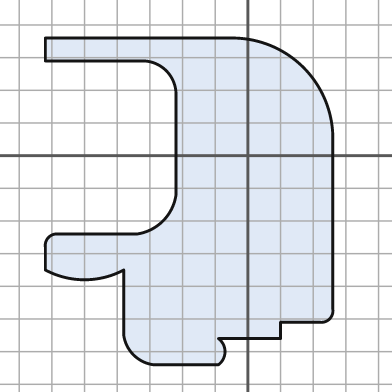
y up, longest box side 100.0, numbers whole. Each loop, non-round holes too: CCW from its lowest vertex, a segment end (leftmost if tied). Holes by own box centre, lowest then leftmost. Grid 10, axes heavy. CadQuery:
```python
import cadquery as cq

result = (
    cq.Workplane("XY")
    .moveTo(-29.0, -64.0)
    .lineTo(-9.0, -64.0)
    .threePointArc((-7.0, -60.0), (-9.0, -56.0))
    .lineTo(10.0, -56.0)
    .lineTo(10.0, -51.0)
    .lineTo(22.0, -51.0)
    .threePointArc((25.0, -50.0), (26.0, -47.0))
    .lineTo(26.0, 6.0)
    .threePointArc((17.0, 27.0), (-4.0, 36.0))
    .lineTo(-62.0, 36.0)
    .lineTo(-62.0, 29.0)
    .lineTo(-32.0, 29.0)
    .threePointArc((-25.0, 26.0), (-22.0, 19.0))
    .lineTo(-22.0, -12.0)
    .threePointArc((-26.0, -20.0), (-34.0, -24.0))
    .lineTo(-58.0, -24.0)
    .threePointArc((-61.0, -25.0), (-62.0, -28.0))
    .lineTo(-62.0, -35.0)
    .threePointArc((-50.0, -38.0), (-38.0, -35.0))
    .lineTo(-38.0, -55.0)
    .threePointArc((-35.0, -61.0), (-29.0, -64.0))
    .close()
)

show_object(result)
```